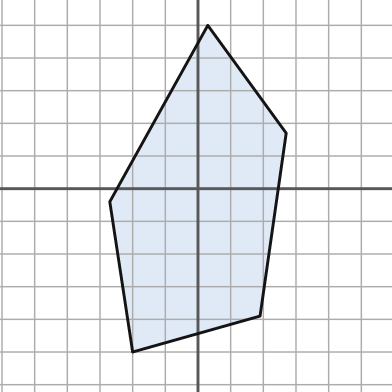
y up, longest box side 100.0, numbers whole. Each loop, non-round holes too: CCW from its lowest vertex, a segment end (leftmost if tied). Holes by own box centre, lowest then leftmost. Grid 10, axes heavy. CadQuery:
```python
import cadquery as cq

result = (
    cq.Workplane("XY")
    .moveTo(-20.0, -50.0)
    .lineTo(19.0, -39.0)
    .lineTo(27.0, 17.0)
    .lineTo(3.0, 50.0)
    .lineTo(-27.0, -4.0)
    .close()
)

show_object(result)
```